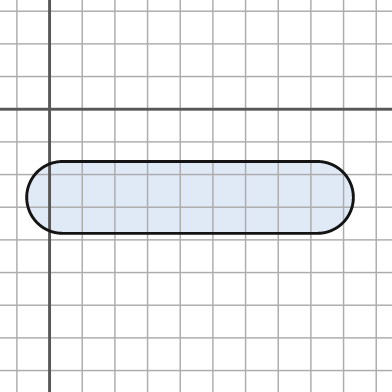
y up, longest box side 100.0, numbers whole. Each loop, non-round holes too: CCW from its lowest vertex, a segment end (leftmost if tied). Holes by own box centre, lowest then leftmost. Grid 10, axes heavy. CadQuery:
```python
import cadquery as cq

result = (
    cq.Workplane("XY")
    .moveTo(4.0, -38.0)
    .lineTo(82.0, -38.0)
    .threePointArc((93.0, -27.0), (82.0, -16.0))
    .lineTo(4.0, -16.0)
    .threePointArc((-7.0, -27.0), (4.0, -38.0))
    .close()
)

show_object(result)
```